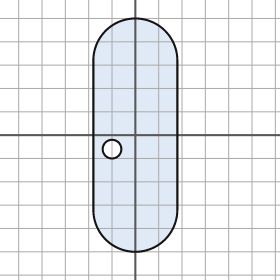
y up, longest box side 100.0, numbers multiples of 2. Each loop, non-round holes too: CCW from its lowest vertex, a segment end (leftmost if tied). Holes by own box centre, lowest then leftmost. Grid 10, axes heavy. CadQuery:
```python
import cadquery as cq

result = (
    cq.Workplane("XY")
    .moveTo(-18.0, -32.0)
    .threePointArc((0.0, -50.0), (18.0, -32.0))
    .lineTo(18.0, 32.0)
    .threePointArc((0.0, 50.0), (-18.0, 32.0))
    .close()
    .moveTo(-10.0, -6.0)
    .circle(4.0)
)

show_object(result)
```